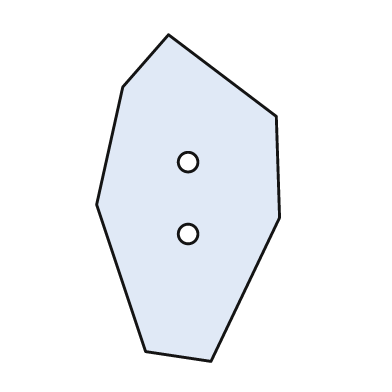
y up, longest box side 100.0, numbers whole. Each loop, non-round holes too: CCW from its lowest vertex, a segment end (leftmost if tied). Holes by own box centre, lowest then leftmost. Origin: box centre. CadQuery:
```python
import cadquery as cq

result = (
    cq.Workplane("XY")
    .moveTo(7.0, -50.0)
    .lineTo(28.0, -6.0)
    .lineTo(27.0, 25.0)
    .lineTo(-6.0, 50.0)
    .lineTo(-20.0, 34.0)
    .lineTo(-28.0, -2.0)
    .lineTo(-13.0, -47.0)
    .close()
    .moveTo(0.0, -11.0)
    .circle(3.0)
    .moveTo(0.0, 11.0)
    .circle(3.0)
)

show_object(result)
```